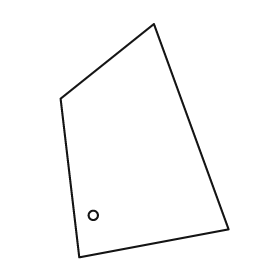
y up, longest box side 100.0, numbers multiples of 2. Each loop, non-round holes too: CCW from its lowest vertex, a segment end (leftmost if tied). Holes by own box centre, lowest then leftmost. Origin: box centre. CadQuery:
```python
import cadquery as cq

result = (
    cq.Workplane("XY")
    .moveTo(-28.0, -50.0)
    .lineTo(36.0, -38.0)
    .lineTo(4.0, 50.0)
    .lineTo(-36.0, 18.0)
    .close()
    .moveTo(-22.0, -32.0)
    .circle(2.0)
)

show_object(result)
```